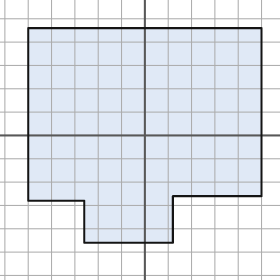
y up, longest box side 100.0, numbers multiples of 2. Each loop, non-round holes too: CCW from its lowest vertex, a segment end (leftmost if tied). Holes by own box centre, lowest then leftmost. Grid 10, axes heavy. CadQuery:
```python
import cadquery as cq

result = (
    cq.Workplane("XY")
    .moveTo(-26.0, -46.0)
    .lineTo(12.0, -46.0)
    .lineTo(12.0, -26.0)
    .lineTo(50.0, -26.0)
    .lineTo(50.0, 46.0)
    .lineTo(-50.0, 46.0)
    .lineTo(-50.0, -28.0)
    .lineTo(-26.0, -28.0)
    .close()
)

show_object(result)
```